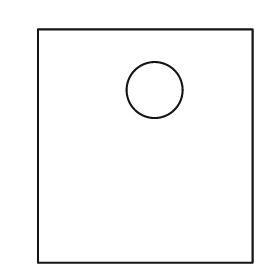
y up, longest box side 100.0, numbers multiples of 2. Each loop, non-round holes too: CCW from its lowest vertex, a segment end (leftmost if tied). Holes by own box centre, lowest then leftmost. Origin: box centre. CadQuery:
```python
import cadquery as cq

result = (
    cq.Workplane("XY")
    .moveTo(-46.0, -50.0)
    .lineTo(46.0, -50.0)
    .lineTo(46.0, 50.0)
    .lineTo(-46.0, 50.0)
    .close()
    .moveTo(4.0, 24.0)
    .circle(12.0)
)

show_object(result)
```